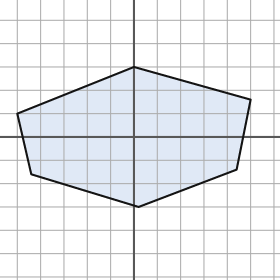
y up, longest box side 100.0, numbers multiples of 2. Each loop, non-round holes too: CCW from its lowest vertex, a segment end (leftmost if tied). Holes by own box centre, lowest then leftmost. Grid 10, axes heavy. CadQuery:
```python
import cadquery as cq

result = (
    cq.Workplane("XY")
    .moveTo(2.0, -30.0)
    .lineTo(44.0, -14.0)
    .lineTo(50.0, 16.0)
    .lineTo(0.0, 30.0)
    .lineTo(-50.0, 10.0)
    .lineTo(-44.0, -16.0)
    .close()
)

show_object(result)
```